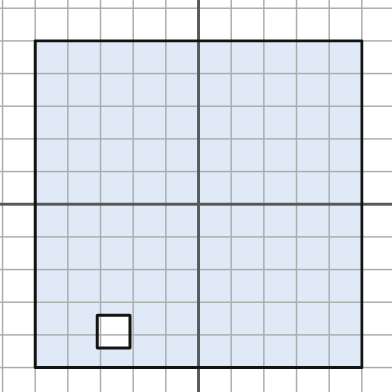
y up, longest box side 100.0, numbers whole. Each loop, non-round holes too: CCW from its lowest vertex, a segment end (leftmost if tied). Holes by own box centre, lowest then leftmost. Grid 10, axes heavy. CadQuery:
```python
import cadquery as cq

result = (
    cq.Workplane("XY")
    .moveTo(-50.0, -50.0)
    .lineTo(50.0, -50.0)
    .lineTo(50.0, 50.0)
    .lineTo(-50.0, 50.0)
    .close()
    .moveTo(-31.0, -44.0)
    .lineTo(-21.0, -44.0)
    .lineTo(-21.0, -34.0)
    .lineTo(-31.0, -34.0)
    .close()
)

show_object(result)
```